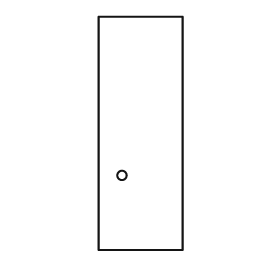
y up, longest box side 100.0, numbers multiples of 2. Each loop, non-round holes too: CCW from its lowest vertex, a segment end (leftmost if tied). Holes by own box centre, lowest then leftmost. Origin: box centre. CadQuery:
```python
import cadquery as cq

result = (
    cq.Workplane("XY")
    .moveTo(-18.0, -50.0)
    .lineTo(18.0, -50.0)
    .lineTo(18.0, 50.0)
    .lineTo(-18.0, 50.0)
    .close()
    .moveTo(-8.0, -18.0)
    .circle(2.0)
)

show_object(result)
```